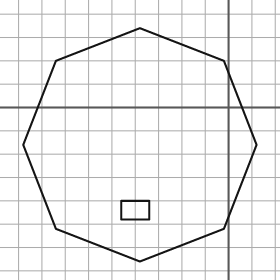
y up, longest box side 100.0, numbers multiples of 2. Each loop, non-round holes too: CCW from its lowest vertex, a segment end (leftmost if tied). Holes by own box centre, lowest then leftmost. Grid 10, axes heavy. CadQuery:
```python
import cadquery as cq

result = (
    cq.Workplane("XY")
    .moveTo(-38.0, -66.0)
    .lineTo(-2.0, -52.0)
    .lineTo(12.0, -16.0)
    .lineTo(-2.0, 20.0)
    .lineTo(-38.0, 34.0)
    .lineTo(-74.0, 20.0)
    .lineTo(-88.0, -16.0)
    .lineTo(-74.0, -52.0)
    .close()
    .moveTo(-46.0, -48.0)
    .lineTo(-34.0, -48.0)
    .lineTo(-34.0, -40.0)
    .lineTo(-46.0, -40.0)
    .close()
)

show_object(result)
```